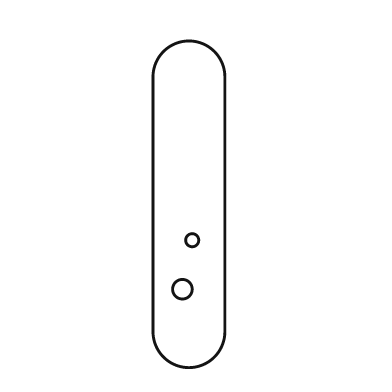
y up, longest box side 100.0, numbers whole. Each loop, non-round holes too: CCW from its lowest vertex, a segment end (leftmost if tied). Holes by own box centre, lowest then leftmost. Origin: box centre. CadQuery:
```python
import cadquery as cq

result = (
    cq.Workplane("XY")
    .moveTo(-11.0, -39.0)
    .threePointArc((0.0, -50.0), (11.0, -39.0))
    .lineTo(11.0, 39.0)
    .threePointArc((0.0, 50.0), (-11.0, 39.0))
    .close()
    .moveTo(-2.0, -26.0)
    .circle(3.0)
    .moveTo(1.0, -11.0)
    .circle(2.0)
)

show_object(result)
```